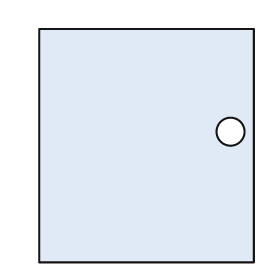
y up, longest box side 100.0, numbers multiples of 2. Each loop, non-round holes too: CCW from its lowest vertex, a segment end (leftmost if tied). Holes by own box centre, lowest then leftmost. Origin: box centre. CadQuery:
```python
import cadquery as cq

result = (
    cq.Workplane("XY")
    .moveTo(-46.0, -50.0)
    .lineTo(46.0, -50.0)
    .lineTo(46.0, 50.0)
    .lineTo(-46.0, 50.0)
    .close()
    .moveTo(36.0, 6.0)
    .circle(6.0)
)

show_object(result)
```